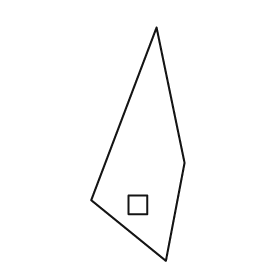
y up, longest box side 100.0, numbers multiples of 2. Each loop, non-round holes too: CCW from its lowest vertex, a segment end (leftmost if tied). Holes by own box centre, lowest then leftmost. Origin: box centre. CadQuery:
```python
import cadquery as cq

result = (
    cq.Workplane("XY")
    .moveTo(12.0, -50.0)
    .lineTo(20.0, -8.0)
    .lineTo(8.0, 50.0)
    .lineTo(-20.0, -24.0)
    .close()
    .moveTo(-4.0, -30.0)
    .lineTo(4.0, -30.0)
    .lineTo(4.0, -22.0)
    .lineTo(-4.0, -22.0)
    .close()
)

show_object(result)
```